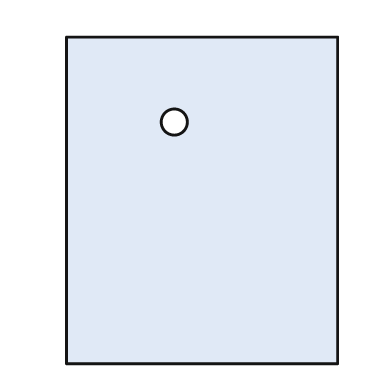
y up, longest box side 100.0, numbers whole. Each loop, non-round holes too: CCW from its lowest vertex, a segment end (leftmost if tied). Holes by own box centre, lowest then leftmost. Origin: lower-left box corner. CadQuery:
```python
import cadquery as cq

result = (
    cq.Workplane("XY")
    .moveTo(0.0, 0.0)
    .lineTo(83.0, 0.0)
    .lineTo(83.0, 100.0)
    .lineTo(0.0, 100.0)
    .close()
    .moveTo(33.0, 74.0)
    .circle(4.0)
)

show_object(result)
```